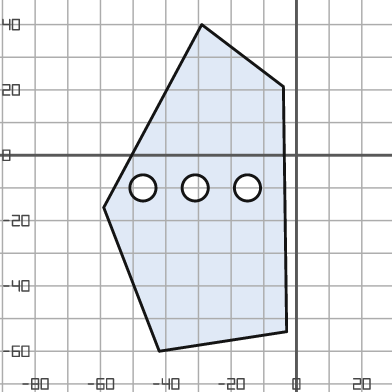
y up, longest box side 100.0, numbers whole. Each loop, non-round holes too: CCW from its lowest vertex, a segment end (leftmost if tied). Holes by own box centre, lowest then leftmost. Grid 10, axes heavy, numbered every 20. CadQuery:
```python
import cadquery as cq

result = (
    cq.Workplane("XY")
    .moveTo(-42.0, -60.0)
    .lineTo(-3.0, -54.0)
    .lineTo(-4.0, 21.0)
    .lineTo(-29.0, 40.0)
    .lineTo(-59.0, -16.0)
    .close()
    .moveTo(-47.0, -10.0)
    .circle(4.0)
    .moveTo(-31.0, -10.0)
    .circle(4.0)
    .moveTo(-15.0, -10.0)
    .circle(4.0)
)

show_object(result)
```